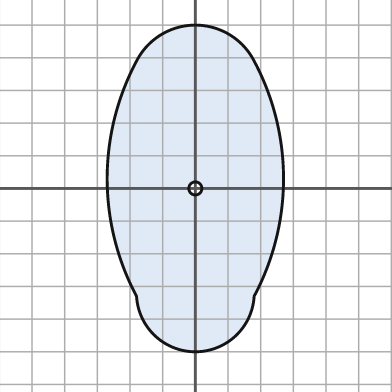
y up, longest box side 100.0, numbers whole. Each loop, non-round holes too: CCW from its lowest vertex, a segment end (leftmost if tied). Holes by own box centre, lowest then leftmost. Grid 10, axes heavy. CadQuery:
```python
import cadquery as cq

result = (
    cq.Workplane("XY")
    .moveTo(-18.0, -33.0)
    .threePointArc((0.0, -50.0), (18.0, -33.0))
    .threePointArc((27.0, 3.0), (18.0, 39.0))
    .threePointArc((0.0, 50.0), (-18.0, 39.0))
    .threePointArc((-27.0, 3.0), (-18.0, -33.0))
    .close()
    .moveTo(0.0, 0.0)
    .circle(2.0)
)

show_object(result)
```